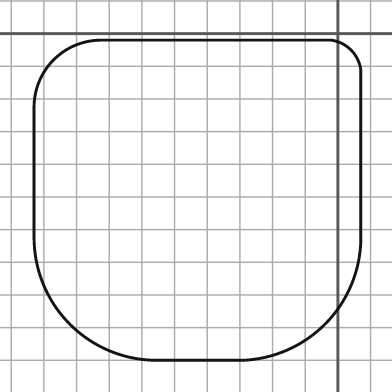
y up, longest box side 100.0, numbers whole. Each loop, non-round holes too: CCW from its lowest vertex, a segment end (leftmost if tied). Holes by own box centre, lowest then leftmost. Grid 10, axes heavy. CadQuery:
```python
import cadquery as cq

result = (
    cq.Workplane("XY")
    .moveTo(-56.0, -100.0)
    .lineTo(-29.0, -100.0)
    .threePointArc((-4.0, -89.0), (7.0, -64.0))
    .lineTo(7.0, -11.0)
    .threePointArc((4.0, -5.0), (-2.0, -2.0))
    .lineTo(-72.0, -2.0)
    .threePointArc((-87.0, -8.0), (-93.0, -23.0))
    .lineTo(-93.0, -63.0)
    .threePointArc((-82.0, -89.0), (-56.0, -100.0))
    .close()
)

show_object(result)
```